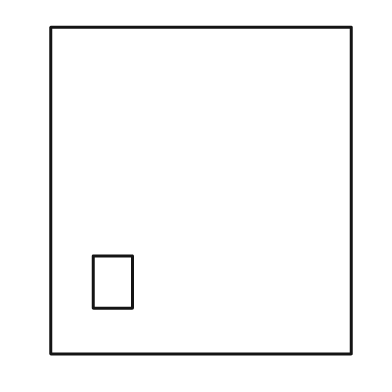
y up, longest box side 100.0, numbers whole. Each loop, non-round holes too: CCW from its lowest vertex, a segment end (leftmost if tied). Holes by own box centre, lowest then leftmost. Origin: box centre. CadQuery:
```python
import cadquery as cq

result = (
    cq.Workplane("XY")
    .moveTo(-46.0, -50.0)
    .lineTo(46.0, -50.0)
    .lineTo(46.0, 50.0)
    .lineTo(-46.0, 50.0)
    .close()
    .moveTo(-33.0, -36.0)
    .lineTo(-21.0, -36.0)
    .lineTo(-21.0, -20.0)
    .lineTo(-33.0, -20.0)
    .close()
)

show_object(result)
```